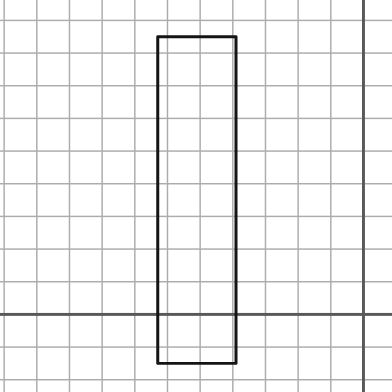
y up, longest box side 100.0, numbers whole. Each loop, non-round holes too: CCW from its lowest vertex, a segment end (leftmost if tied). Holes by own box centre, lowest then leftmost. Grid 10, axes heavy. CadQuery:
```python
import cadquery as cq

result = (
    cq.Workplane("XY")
    .moveTo(-63.0, -15.0)
    .lineTo(-39.0, -15.0)
    .lineTo(-39.0, 85.0)
    .lineTo(-63.0, 85.0)
    .close()
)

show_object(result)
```